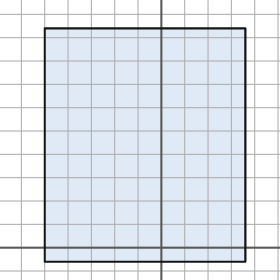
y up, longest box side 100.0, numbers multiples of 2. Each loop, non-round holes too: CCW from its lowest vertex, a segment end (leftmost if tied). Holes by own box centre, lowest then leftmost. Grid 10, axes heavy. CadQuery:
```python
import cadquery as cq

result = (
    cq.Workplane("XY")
    .moveTo(-50.0, -6.0)
    .lineTo(36.0, -6.0)
    .lineTo(36.0, 94.0)
    .lineTo(-50.0, 94.0)
    .close()
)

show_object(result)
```